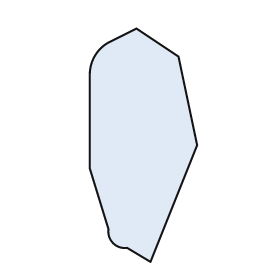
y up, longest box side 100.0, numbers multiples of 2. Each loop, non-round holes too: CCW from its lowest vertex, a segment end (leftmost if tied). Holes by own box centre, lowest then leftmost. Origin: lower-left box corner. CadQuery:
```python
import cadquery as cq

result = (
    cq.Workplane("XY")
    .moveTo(26.0, 0.0)
    .lineTo(46.0, 50.0)
    .lineTo(38.0, 88.0)
    .lineTo(20.0, 100.0)
    .lineTo(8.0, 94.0)
    .threePointArc((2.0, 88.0), (0.0, 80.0))
    .lineTo(0.0, 40.0)
    .lineTo(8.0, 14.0)
    .threePointArc((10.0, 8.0), (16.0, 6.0))
    .close()
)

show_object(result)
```